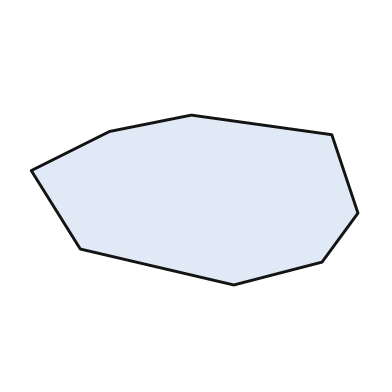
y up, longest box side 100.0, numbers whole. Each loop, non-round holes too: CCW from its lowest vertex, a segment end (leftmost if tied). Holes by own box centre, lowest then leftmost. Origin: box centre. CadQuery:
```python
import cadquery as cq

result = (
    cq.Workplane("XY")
    .moveTo(12.0, -26.0)
    .lineTo(39.0, -19.0)
    .lineTo(50.0, -4.0)
    .lineTo(42.0, 20.0)
    .lineTo(-1.0, 26.0)
    .lineTo(-26.0, 21.0)
    .lineTo(-50.0, 9.0)
    .lineTo(-35.0, -15.0)
    .close()
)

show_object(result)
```